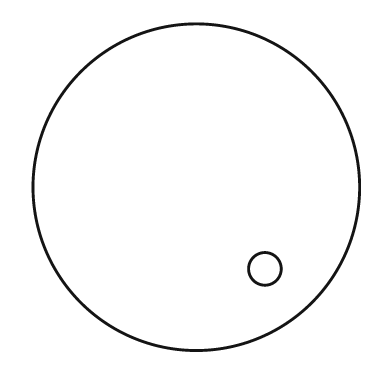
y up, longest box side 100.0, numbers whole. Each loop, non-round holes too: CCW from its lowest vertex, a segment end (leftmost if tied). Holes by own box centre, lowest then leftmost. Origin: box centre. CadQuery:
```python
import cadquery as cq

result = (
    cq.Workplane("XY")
    .moveTo(0.0, 0.0)
    .circle(50.0)
    .moveTo(21.0, -25.0)
    .circle(5.0)
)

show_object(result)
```